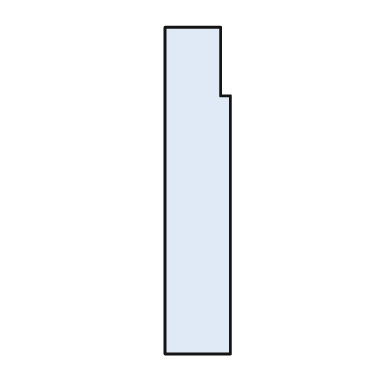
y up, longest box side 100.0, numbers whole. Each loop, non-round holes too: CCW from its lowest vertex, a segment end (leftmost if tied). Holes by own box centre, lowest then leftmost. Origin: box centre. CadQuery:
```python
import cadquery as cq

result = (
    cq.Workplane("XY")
    .moveTo(-10.0, -50.0)
    .lineTo(10.0, -50.0)
    .lineTo(10.0, 29.0)
    .lineTo(7.0, 29.0)
    .lineTo(7.0, 50.0)
    .lineTo(-10.0, 50.0)
    .close()
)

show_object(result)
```